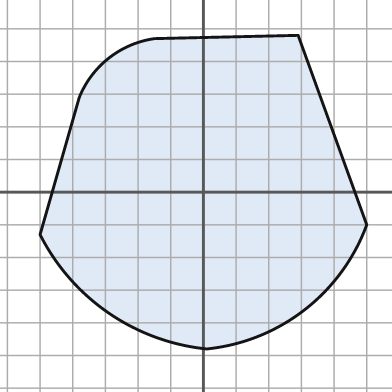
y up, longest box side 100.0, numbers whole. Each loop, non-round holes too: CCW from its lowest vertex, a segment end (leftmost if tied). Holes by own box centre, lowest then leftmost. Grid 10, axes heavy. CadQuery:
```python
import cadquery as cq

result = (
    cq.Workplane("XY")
    .moveTo(1.0, -48.0)
    .threePointArc((31.0, -36.0), (50.0, -10.0))
    .lineTo(29.0, 48.0)
    .lineTo(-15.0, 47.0)
    .threePointArc((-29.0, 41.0), (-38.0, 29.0))
    .lineTo(-50.0, -13.0)
    .threePointArc((-29.0, -37.0), (1.0, -48.0))
    .close()
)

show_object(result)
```